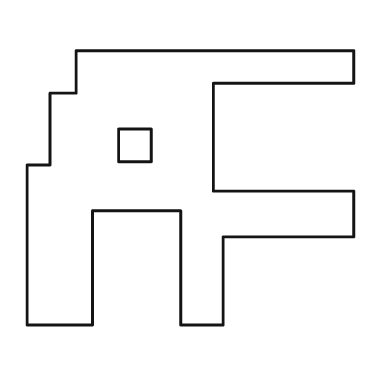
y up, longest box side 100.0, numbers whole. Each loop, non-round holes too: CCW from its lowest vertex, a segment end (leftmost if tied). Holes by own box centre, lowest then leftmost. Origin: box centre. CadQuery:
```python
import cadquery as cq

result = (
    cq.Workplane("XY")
    .moveTo(-50.0, -42.0)
    .lineTo(-30.0, -42.0)
    .lineTo(-30.0, -7.0)
    .lineTo(-3.0, -7.0)
    .lineTo(-3.0, -42.0)
    .lineTo(10.0, -42.0)
    .lineTo(10.0, -15.0)
    .lineTo(50.0, -15.0)
    .lineTo(50.0, -1.0)
    .lineTo(7.0, -1.0)
    .lineTo(7.0, 32.0)
    .lineTo(50.0, 32.0)
    .lineTo(50.0, 42.0)
    .lineTo(-35.0, 42.0)
    .lineTo(-35.0, 29.0)
    .lineTo(-43.0, 29.0)
    .lineTo(-43.0, 7.0)
    .lineTo(-50.0, 7.0)
    .close()
    .moveTo(-22.0, 8.0)
    .lineTo(-12.0, 8.0)
    .lineTo(-12.0, 18.0)
    .lineTo(-22.0, 18.0)
    .close()
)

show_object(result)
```